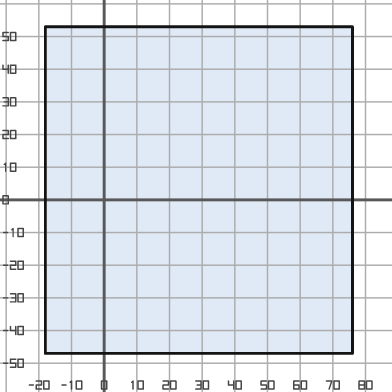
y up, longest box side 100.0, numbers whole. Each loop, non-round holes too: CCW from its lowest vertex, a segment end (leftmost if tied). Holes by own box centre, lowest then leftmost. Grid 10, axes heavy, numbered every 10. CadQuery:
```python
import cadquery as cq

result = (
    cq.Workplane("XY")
    .moveTo(-18.0, -47.0)
    .lineTo(76.0, -47.0)
    .lineTo(76.0, 53.0)
    .lineTo(-18.0, 53.0)
    .close()
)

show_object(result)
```